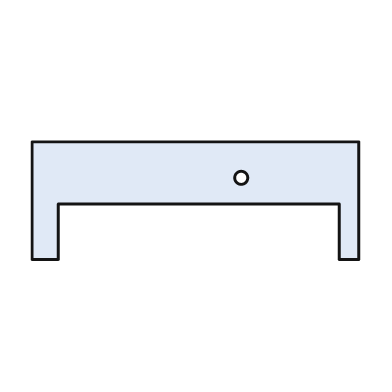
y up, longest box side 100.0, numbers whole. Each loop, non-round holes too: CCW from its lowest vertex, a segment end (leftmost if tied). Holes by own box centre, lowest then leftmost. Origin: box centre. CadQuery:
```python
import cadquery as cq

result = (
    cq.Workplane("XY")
    .moveTo(-50.0, -18.0)
    .lineTo(-42.0, -18.0)
    .lineTo(-42.0, -1.0)
    .lineTo(44.0, -1.0)
    .lineTo(44.0, -18.0)
    .lineTo(50.0, -18.0)
    .lineTo(50.0, 18.0)
    .lineTo(-50.0, 18.0)
    .close()
    .moveTo(14.0, 7.0)
    .circle(2.0)
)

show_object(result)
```